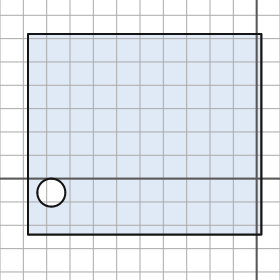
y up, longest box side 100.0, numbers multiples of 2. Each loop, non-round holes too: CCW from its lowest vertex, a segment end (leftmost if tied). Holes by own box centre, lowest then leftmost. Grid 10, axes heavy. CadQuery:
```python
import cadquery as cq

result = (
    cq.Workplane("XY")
    .moveTo(-98.0, -24.0)
    .lineTo(2.0, -24.0)
    .lineTo(2.0, 62.0)
    .lineTo(-98.0, 62.0)
    .close()
    .moveTo(-88.0, -6.0)
    .circle(6.0)
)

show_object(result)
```